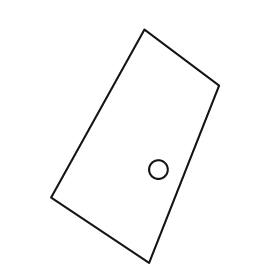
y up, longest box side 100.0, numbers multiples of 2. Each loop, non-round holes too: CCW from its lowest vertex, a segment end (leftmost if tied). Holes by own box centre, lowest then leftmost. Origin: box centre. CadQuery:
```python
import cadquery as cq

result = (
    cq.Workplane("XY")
    .moveTo(6.0, -50.0)
    .lineTo(36.0, 26.0)
    .lineTo(4.0, 50.0)
    .lineTo(-36.0, -22.0)
    .close()
    .moveTo(10.0, -10.0)
    .circle(4.0)
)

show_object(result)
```